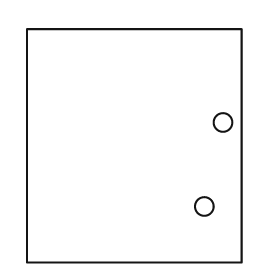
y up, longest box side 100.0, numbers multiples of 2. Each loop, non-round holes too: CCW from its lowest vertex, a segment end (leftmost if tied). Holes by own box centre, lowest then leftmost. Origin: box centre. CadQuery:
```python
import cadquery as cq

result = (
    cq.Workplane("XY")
    .moveTo(-46.0, -50.0)
    .lineTo(46.0, -50.0)
    .lineTo(46.0, 50.0)
    .lineTo(-46.0, 50.0)
    .close()
    .moveTo(30.0, -26.0)
    .circle(4.0)
    .moveTo(38.0, 10.0)
    .circle(4.0)
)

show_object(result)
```